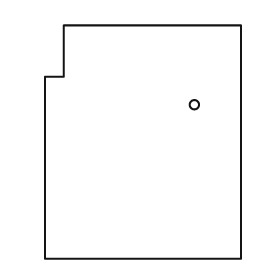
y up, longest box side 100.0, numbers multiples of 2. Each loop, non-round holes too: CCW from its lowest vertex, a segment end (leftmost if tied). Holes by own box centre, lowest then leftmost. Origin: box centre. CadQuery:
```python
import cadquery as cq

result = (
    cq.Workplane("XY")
    .moveTo(-42.0, -50.0)
    .lineTo(42.0, -50.0)
    .lineTo(42.0, 50.0)
    .lineTo(-34.0, 50.0)
    .lineTo(-34.0, 28.0)
    .lineTo(-42.0, 28.0)
    .close()
    .moveTo(22.0, 16.0)
    .circle(2.0)
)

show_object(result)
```